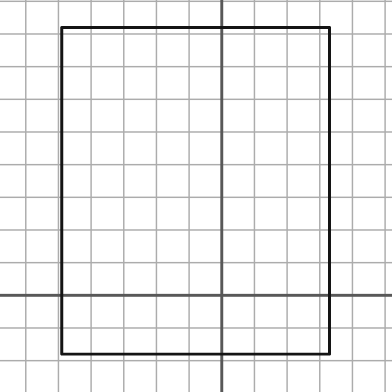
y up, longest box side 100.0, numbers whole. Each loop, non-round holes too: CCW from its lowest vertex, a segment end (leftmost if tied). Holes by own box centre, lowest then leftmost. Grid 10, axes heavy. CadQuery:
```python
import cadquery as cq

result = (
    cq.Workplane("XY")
    .moveTo(-49.0, -18.0)
    .lineTo(33.0, -18.0)
    .lineTo(33.0, 82.0)
    .lineTo(-49.0, 82.0)
    .close()
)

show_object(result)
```